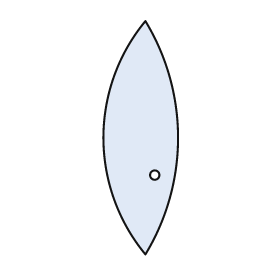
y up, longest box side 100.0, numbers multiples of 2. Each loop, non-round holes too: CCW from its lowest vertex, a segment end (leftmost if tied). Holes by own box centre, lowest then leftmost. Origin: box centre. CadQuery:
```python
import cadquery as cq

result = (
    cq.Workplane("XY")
    .moveTo(2.0, -50.0)
    .threePointArc((16.0, 0.0), (2.0, 50.0))
    .threePointArc((-16.0, 0.0), (2.0, -50.0))
    .close()
    .moveTo(6.0, -16.0)
    .circle(2.0)
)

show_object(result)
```